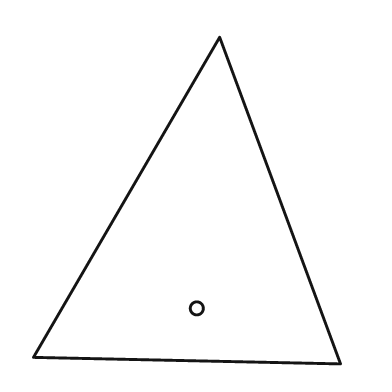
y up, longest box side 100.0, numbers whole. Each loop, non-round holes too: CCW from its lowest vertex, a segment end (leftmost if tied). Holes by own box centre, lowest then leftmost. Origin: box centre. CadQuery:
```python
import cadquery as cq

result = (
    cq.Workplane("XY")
    .moveTo(47.0, -50.0)
    .lineTo(10.0, 50.0)
    .lineTo(-47.0, -48.0)
    .close()
    .moveTo(3.0, -33.0)
    .circle(2.0)
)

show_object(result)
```